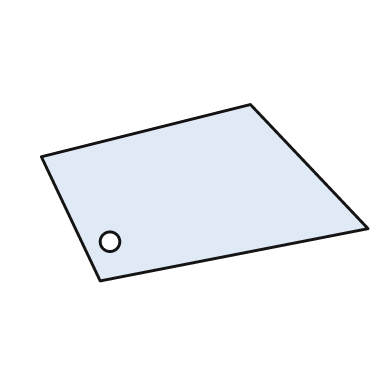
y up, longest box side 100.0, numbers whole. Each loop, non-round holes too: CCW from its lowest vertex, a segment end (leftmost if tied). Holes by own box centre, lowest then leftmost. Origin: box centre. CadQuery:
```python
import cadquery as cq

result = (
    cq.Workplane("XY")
    .moveTo(-32.0, -27.0)
    .lineTo(50.0, -11.0)
    .lineTo(14.0, 27.0)
    .lineTo(-50.0, 11.0)
    .close()
    .moveTo(-29.0, -15.0)
    .circle(3.0)
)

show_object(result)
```